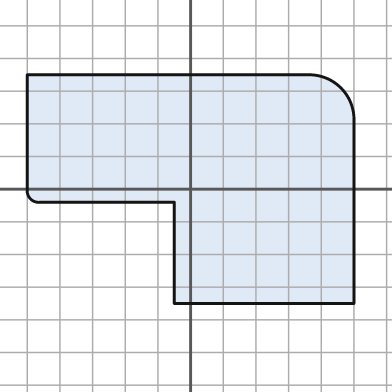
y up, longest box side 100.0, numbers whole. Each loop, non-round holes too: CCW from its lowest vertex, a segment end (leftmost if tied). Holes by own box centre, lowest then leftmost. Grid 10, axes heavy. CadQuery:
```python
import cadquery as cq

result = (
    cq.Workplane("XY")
    .moveTo(-5.0, -35.0)
    .lineTo(50.0, -35.0)
    .lineTo(50.0, 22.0)
    .threePointArc((46.0, 31.0), (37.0, 35.0))
    .lineTo(-50.0, 35.0)
    .lineTo(-50.0, 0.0)
    .threePointArc((-49.0, -3.0), (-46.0, -4.0))
    .lineTo(-5.0, -4.0)
    .close()
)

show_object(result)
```